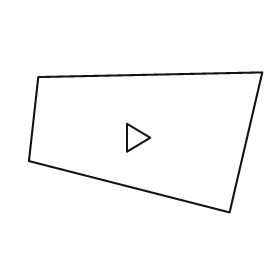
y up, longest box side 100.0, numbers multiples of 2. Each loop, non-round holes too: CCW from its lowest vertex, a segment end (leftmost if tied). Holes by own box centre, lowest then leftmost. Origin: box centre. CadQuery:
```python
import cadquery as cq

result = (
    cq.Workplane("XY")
    .moveTo(36.0, -30.0)
    .lineTo(50.0, 30.0)
    .lineTo(-46.0, 28.0)
    .lineTo(-50.0, -8.0)
    .close()
    .moveTo(-8.0, -4.0)
    .lineTo(2.0, 2.0)
    .lineTo(-8.0, 8.0)
    .close()
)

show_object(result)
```